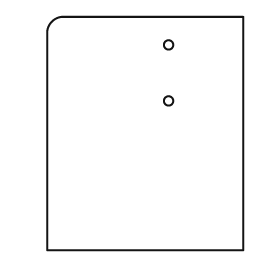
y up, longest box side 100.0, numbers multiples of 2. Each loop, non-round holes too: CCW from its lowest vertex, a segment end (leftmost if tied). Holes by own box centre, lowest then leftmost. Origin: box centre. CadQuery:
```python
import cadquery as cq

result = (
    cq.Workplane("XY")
    .moveTo(-42.0, -50.0)
    .lineTo(42.0, -50.0)
    .lineTo(42.0, 50.0)
    .lineTo(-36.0, 50.0)
    .threePointArc((-40.0, 48.0), (-42.0, 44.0))
    .close()
    .moveTo(10.0, 14.0)
    .circle(2.0)
    .moveTo(10.0, 38.0)
    .circle(2.0)
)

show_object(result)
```